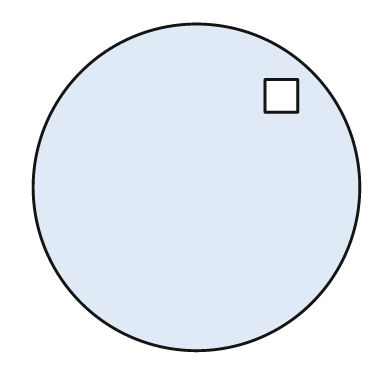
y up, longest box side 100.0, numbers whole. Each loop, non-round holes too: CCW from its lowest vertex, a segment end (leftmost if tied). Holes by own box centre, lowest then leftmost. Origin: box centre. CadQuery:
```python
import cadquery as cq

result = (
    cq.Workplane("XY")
    .moveTo(0.0, 0.0)
    .circle(50.0)
    .moveTo(21.0, 23.0)
    .lineTo(31.0, 23.0)
    .lineTo(31.0, 33.0)
    .lineTo(21.0, 33.0)
    .close()
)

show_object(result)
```